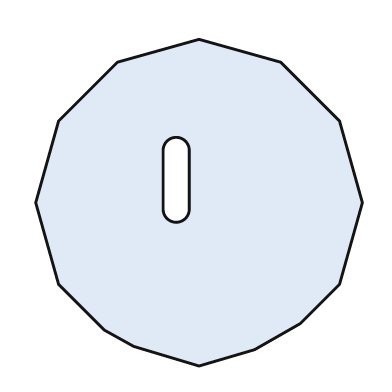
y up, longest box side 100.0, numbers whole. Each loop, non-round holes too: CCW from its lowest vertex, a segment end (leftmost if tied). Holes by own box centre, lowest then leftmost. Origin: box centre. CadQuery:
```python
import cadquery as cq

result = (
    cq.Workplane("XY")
    .moveTo(0.0, -50.0)
    .lineTo(17.0, -45.0)
    .lineTo(31.0, -37.0)
    .lineTo(43.0, -25.0)
    .lineTo(50.0, 0.0)
    .lineTo(43.0, 25.0)
    .lineTo(25.0, 43.0)
    .lineTo(0.0, 50.0)
    .lineTo(-25.0, 43.0)
    .lineTo(-43.0, 25.0)
    .lineTo(-50.0, 0.0)
    .lineTo(-43.0, -25.0)
    .lineTo(-29.0, -39.0)
    .lineTo(-20.0, -44.0)
    .close()
    .moveTo(-11.0, -2.0)
    .threePointArc((-7.0, -6.0), (-3.0, -2.0))
    .lineTo(-3.0, 16.0)
    .threePointArc((-7.0, 20.0), (-11.0, 16.0))
    .close()
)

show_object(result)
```